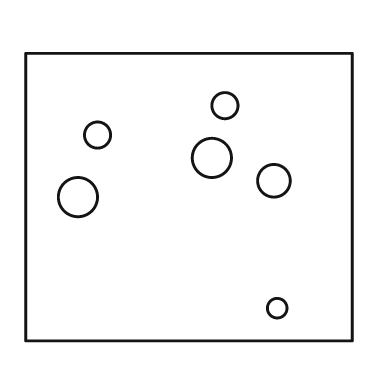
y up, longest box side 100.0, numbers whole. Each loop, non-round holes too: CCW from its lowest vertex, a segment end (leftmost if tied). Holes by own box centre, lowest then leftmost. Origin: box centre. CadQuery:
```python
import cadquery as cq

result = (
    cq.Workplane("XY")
    .moveTo(-50.0, -44.0)
    .lineTo(50.0, -44.0)
    .lineTo(50.0, 44.0)
    .lineTo(-50.0, 44.0)
    .close()
    .moveTo(27.0, -34.0)
    .circle(3.0)
    .moveTo(-34.0, 0.0)
    .circle(6.0)
    .moveTo(26.0, 5.0)
    .circle(5.0)
    .moveTo(7.0, 12.0)
    .circle(6.0)
    .moveTo(-28.0, 19.0)
    .circle(4.0)
    .moveTo(11.0, 28.0)
    .circle(4.0)
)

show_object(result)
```